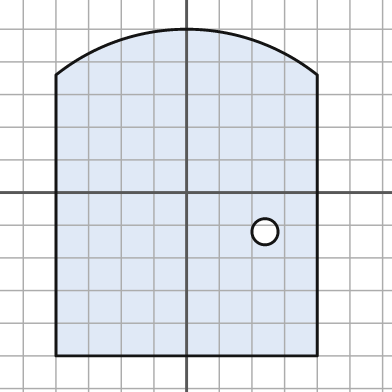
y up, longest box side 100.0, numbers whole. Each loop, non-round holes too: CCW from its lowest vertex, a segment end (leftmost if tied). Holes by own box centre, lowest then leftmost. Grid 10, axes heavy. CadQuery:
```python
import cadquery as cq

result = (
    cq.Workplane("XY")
    .moveTo(-40.0, -50.0)
    .lineTo(40.0, -50.0)
    .lineTo(40.0, 36.0)
    .threePointArc((0.0, 50.0), (-40.0, 36.0))
    .close()
    .moveTo(24.0, -12.0)
    .circle(4.0)
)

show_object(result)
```